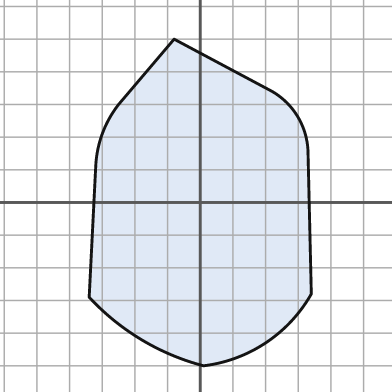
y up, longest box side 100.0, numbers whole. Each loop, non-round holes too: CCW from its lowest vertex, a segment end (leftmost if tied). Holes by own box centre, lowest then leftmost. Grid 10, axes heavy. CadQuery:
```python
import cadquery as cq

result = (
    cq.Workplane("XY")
    .moveTo(1.0, -50.0)
    .threePointArc((20.0, -43.0), (34.0, -28.0))
    .lineTo(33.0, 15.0)
    .threePointArc((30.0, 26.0), (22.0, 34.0))
    .lineTo(-8.0, 50.0)
    .lineTo(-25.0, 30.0)
    .threePointArc((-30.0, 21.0), (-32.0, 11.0))
    .lineTo(-34.0, -29.0)
    .threePointArc((-18.0, -42.0), (1.0, -50.0))
    .close()
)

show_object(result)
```